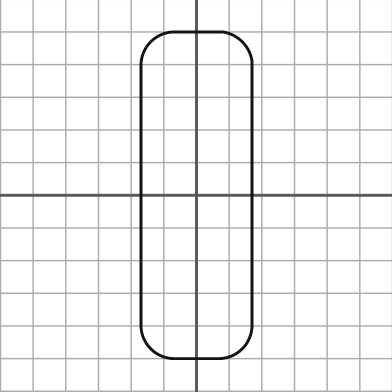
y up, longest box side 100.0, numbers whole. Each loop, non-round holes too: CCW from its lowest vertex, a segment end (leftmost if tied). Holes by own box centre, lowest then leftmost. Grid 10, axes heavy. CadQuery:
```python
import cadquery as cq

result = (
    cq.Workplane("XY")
    .moveTo(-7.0, -50.0)
    .lineTo(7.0, -50.0)
    .threePointArc((14.0, -47.0), (17.0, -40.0))
    .lineTo(17.0, 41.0)
    .threePointArc((14.0, 47.0), (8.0, 50.0))
    .lineTo(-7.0, 50.0)
    .threePointArc((-14.0, 47.0), (-17.0, 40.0))
    .lineTo(-17.0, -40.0)
    .threePointArc((-14.0, -47.0), (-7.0, -50.0))
    .close()
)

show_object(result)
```